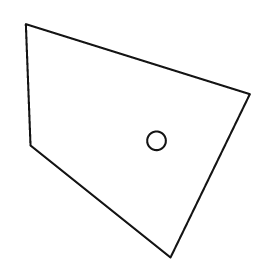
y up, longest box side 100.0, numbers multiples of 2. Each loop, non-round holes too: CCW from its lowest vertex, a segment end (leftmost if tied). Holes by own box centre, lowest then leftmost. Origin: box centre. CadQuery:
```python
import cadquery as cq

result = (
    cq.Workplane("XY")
    .moveTo(14.0, -50.0)
    .lineTo(48.0, 20.0)
    .lineTo(-48.0, 50.0)
    .lineTo(-46.0, -2.0)
    .close()
    .moveTo(8.0, 0.0)
    .circle(4.0)
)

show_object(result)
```